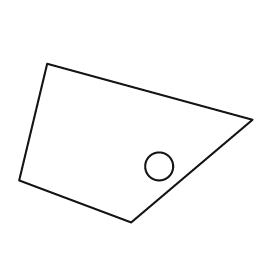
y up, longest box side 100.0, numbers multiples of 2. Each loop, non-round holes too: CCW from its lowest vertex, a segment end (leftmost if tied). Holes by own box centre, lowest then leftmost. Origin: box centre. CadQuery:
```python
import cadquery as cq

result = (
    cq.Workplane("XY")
    .moveTo(-2.0, -34.0)
    .lineTo(50.0, 10.0)
    .lineTo(-38.0, 34.0)
    .lineTo(-50.0, -16.0)
    .close()
    .moveTo(10.0, -10.0)
    .circle(6.0)
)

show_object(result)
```